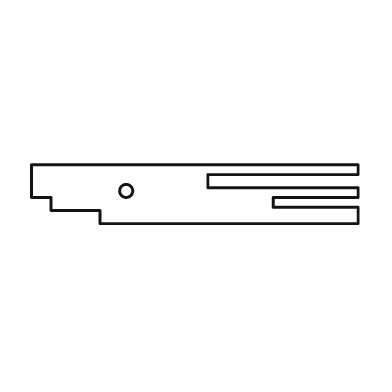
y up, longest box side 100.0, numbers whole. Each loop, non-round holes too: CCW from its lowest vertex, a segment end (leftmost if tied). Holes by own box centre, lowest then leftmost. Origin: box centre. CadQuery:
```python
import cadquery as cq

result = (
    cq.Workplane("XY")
    .moveTo(-29.0, -9.0)
    .lineTo(50.0, -9.0)
    .lineTo(50.0, -4.0)
    .lineTo(24.0, -4.0)
    .lineTo(24.0, -1.0)
    .lineTo(50.0, -1.0)
    .lineTo(50.0, 2.0)
    .lineTo(4.0, 2.0)
    .lineTo(4.0, 6.0)
    .lineTo(50.0, 6.0)
    .lineTo(50.0, 9.0)
    .lineTo(-50.0, 9.0)
    .lineTo(-50.0, -1.0)
    .lineTo(-44.0, -1.0)
    .lineTo(-44.0, -5.0)
    .lineTo(-29.0, -5.0)
    .close()
    .moveTo(-21.0, 1.0)
    .circle(2.0)
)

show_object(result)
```